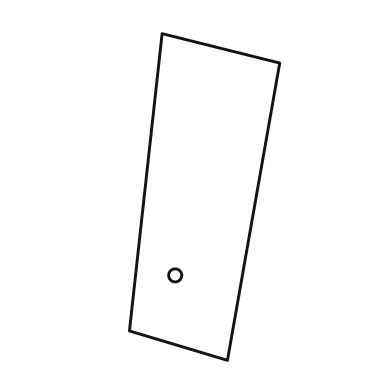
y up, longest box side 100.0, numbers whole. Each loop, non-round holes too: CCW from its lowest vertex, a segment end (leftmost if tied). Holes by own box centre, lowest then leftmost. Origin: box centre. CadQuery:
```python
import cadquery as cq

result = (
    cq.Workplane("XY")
    .moveTo(7.0, -50.0)
    .lineTo(23.0, 41.0)
    .lineTo(-13.0, 50.0)
    .lineTo(-23.0, -41.0)
    .close()
    .moveTo(-9.0, -24.0)
    .circle(2.0)
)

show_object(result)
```